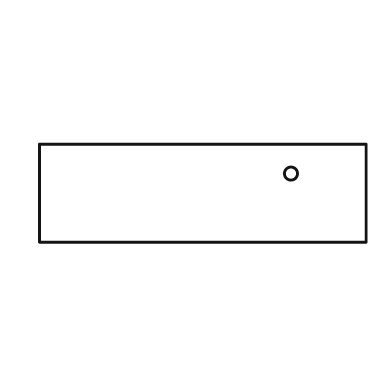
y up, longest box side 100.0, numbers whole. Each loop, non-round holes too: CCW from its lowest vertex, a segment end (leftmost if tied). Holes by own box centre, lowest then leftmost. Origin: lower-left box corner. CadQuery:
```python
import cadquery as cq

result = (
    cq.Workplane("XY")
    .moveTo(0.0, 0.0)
    .lineTo(100.0, 0.0)
    .lineTo(100.0, 30.0)
    .lineTo(0.0, 30.0)
    .close()
    .moveTo(77.0, 21.0)
    .circle(2.0)
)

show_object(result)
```